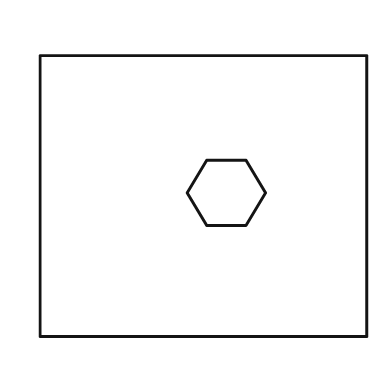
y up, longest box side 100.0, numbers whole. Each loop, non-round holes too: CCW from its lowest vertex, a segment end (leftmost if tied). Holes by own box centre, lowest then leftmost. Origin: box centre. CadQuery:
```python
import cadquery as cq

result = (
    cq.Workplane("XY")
    .moveTo(-50.0, -43.0)
    .lineTo(50.0, -43.0)
    .lineTo(50.0, 43.0)
    .lineTo(-50.0, 43.0)
    .close()
    .moveTo(1.0, -9.0)
    .lineTo(13.0, -9.0)
    .lineTo(19.0, 1.0)
    .lineTo(13.0, 11.0)
    .lineTo(1.0, 11.0)
    .lineTo(-5.0, 1.0)
    .close()
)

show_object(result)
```